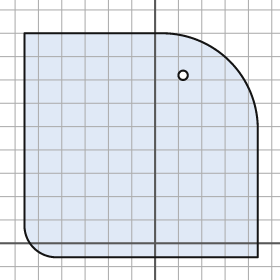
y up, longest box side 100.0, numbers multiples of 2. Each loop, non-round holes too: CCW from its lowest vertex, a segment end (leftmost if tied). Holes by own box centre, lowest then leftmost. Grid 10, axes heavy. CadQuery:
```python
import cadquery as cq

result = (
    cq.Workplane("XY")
    .moveTo(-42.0, -6.0)
    .lineTo(44.0, -6.0)
    .lineTo(44.0, 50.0)
    .threePointArc((32.0, 78.0), (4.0, 90.0))
    .lineTo(-56.0, 90.0)
    .lineTo(-56.0, 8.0)
    .threePointArc((-52.0, -2.0), (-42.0, -6.0))
    .close()
    .moveTo(12.0, 72.0)
    .circle(2.0)
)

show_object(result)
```